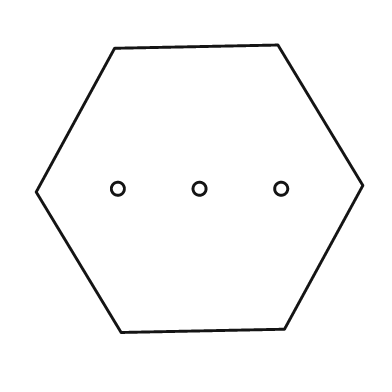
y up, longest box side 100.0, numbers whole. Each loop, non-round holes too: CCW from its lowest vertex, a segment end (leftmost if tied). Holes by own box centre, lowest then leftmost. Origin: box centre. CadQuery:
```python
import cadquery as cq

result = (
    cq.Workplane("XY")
    .moveTo(-24.0, -44.0)
    .lineTo(26.0, -43.0)
    .lineTo(50.0, 1.0)
    .lineTo(24.0, 44.0)
    .lineTo(-26.0, 43.0)
    .lineTo(-50.0, -1.0)
    .close()
    .moveTo(-25.0, 0.0)
    .circle(2.0)
    .moveTo(0.0, 0.0)
    .circle(2.0)
    .moveTo(25.0, 0.0)
    .circle(2.0)
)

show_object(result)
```